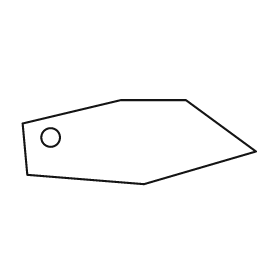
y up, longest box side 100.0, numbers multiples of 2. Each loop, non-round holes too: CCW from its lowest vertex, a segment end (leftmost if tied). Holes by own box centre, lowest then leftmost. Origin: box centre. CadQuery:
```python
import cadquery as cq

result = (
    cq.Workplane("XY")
    .moveTo(2.0, -18.0)
    .lineTo(50.0, -4.0)
    .lineTo(20.0, 18.0)
    .lineTo(-8.0, 18.0)
    .lineTo(-50.0, 8.0)
    .lineTo(-48.0, -14.0)
    .close()
    .moveTo(-38.0, 2.0)
    .circle(4.0)
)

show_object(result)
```